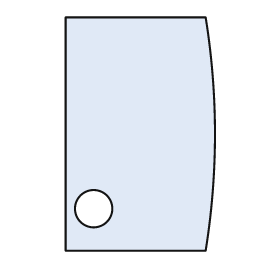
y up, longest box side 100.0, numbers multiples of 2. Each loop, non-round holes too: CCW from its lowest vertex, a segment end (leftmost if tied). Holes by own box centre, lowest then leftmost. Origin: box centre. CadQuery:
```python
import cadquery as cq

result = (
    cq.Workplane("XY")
    .moveTo(-32.0, -50.0)
    .lineTo(28.0, -50.0)
    .threePointArc((32.0, 0.0), (28.0, 50.0))
    .lineTo(-32.0, 50.0)
    .close()
    .moveTo(-20.0, -32.0)
    .circle(8.0)
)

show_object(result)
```